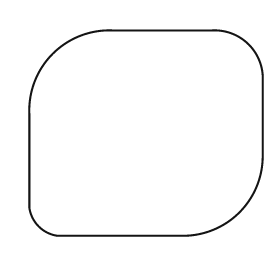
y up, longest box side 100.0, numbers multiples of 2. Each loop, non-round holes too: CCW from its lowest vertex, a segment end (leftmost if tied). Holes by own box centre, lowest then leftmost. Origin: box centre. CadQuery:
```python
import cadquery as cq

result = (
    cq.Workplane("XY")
    .moveTo(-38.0, -44.0)
    .lineTo(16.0, -44.0)
    .threePointArc((40.0, -34.0), (50.0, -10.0))
    .lineTo(50.0, 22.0)
    .threePointArc((44.0, 38.0), (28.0, 44.0))
    .lineTo(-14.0, 44.0)
    .threePointArc((-40.0, 34.0), (-50.0, 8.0))
    .lineTo(-50.0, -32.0)
    .threePointArc((-46.0, -40.0), (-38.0, -44.0))
    .close()
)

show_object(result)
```